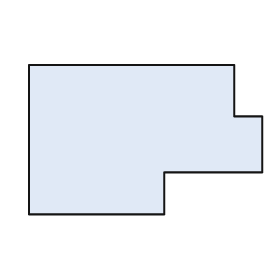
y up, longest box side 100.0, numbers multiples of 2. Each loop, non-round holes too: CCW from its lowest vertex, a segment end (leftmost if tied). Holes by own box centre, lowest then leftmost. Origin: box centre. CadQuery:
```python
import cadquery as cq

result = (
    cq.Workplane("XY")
    .moveTo(-50.0, -32.0)
    .lineTo(8.0, -32.0)
    .lineTo(8.0, -14.0)
    .lineTo(50.0, -14.0)
    .lineTo(50.0, 10.0)
    .lineTo(38.0, 10.0)
    .lineTo(38.0, 32.0)
    .lineTo(-50.0, 32.0)
    .close()
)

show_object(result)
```